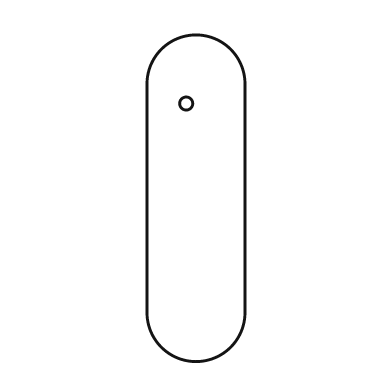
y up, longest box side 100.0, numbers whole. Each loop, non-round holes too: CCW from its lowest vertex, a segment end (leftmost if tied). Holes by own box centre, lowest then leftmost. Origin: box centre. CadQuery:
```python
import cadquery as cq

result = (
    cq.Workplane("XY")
    .moveTo(-15.0, -35.0)
    .threePointArc((0.0, -50.0), (15.0, -35.0))
    .lineTo(15.0, 35.0)
    .threePointArc((0.0, 50.0), (-15.0, 35.0))
    .close()
    .moveTo(-3.0, 29.0)
    .circle(2.0)
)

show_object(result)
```